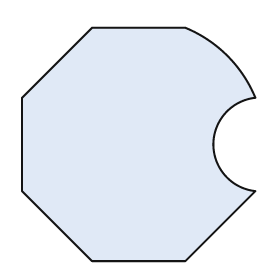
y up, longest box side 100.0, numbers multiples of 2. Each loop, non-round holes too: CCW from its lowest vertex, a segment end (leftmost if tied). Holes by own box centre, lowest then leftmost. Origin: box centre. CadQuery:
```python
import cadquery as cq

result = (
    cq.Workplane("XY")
    .moveTo(-20.0, -50.0)
    .lineTo(20.0, -50.0)
    .lineTo(50.0, -20.0)
    .threePointArc((32.0, 0.0), (50.0, 20.0))
    .threePointArc((38.0, 38.0), (20.0, 50.0))
    .lineTo(-20.0, 50.0)
    .lineTo(-50.0, 20.0)
    .lineTo(-50.0, -20.0)
    .close()
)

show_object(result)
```